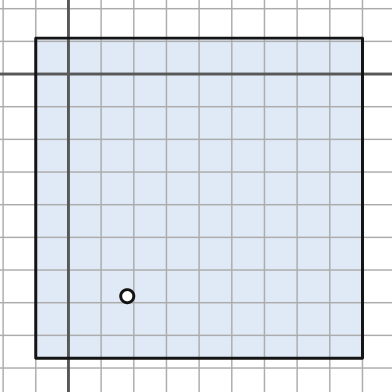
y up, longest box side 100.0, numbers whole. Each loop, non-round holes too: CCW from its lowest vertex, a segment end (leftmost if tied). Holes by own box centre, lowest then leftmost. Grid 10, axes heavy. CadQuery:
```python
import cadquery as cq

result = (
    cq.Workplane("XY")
    .moveTo(-10.0, -87.0)
    .lineTo(90.0, -87.0)
    .lineTo(90.0, 11.0)
    .lineTo(-10.0, 11.0)
    .close()
    .moveTo(18.0, -68.0)
    .circle(2.0)
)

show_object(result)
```